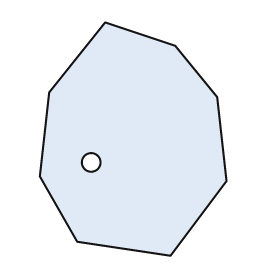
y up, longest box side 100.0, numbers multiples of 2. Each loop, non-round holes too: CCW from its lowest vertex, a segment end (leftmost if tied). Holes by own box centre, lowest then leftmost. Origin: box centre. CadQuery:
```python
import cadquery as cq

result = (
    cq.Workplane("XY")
    .moveTo(16.0, -50.0)
    .lineTo(40.0, -18.0)
    .lineTo(36.0, 18.0)
    .lineTo(18.0, 40.0)
    .lineTo(-12.0, 50.0)
    .lineTo(-36.0, 20.0)
    .lineTo(-40.0, -16.0)
    .lineTo(-24.0, -44.0)
    .close()
    .moveTo(-18.0, -10.0)
    .circle(4.0)
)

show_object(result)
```